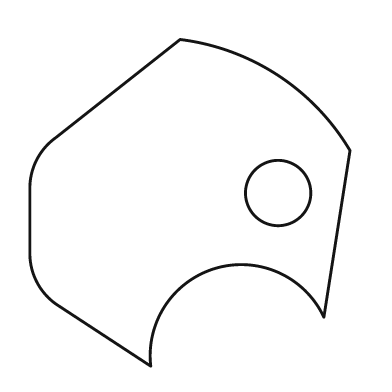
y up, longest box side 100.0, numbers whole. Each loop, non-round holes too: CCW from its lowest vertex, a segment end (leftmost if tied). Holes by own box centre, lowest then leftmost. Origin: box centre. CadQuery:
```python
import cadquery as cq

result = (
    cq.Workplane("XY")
    .moveTo(-12.0, -50.0)
    .threePointArc((8.0, -20.0), (41.0, -35.0))
    .lineTo(49.0, 16.0)
    .threePointArc((27.0, 39.0), (-3.0, 50.0))
    .lineTo(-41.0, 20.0)
    .threePointArc((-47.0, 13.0), (-49.0, 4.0))
    .lineTo(-49.0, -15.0)
    .threePointArc((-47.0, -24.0), (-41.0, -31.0))
    .close()
    .moveTo(27.0, 3.0)
    .circle(10.0)
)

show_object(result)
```